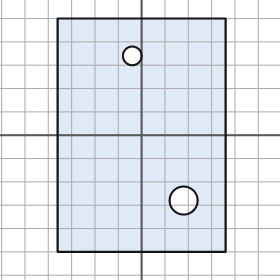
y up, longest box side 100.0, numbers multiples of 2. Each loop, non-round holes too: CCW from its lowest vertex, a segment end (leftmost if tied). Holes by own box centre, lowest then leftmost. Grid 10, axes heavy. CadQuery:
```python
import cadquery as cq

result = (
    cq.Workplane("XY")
    .moveTo(-36.0, -50.0)
    .lineTo(36.0, -50.0)
    .lineTo(36.0, 50.0)
    .lineTo(-36.0, 50.0)
    .close()
    .moveTo(18.0, -28.0)
    .circle(6.0)
    .moveTo(-4.0, 34.0)
    .circle(4.0)
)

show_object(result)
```